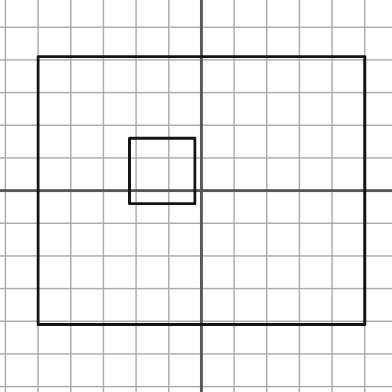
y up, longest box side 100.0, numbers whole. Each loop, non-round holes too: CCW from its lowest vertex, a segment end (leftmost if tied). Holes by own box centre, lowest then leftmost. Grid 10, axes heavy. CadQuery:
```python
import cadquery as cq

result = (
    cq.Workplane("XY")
    .moveTo(-50.0, -41.0)
    .lineTo(50.0, -41.0)
    .lineTo(50.0, 41.0)
    .lineTo(-50.0, 41.0)
    .close()
    .moveTo(-22.0, -4.0)
    .lineTo(-2.0, -4.0)
    .lineTo(-2.0, 16.0)
    .lineTo(-22.0, 16.0)
    .close()
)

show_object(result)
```